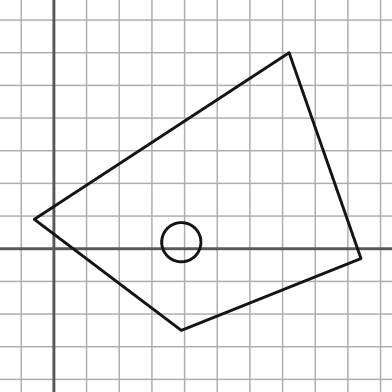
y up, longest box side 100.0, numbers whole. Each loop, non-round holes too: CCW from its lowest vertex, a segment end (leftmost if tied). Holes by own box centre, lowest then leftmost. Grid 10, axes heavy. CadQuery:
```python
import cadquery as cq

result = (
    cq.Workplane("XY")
    .moveTo(39.0, -25.0)
    .lineTo(94.0, -3.0)
    .lineTo(72.0, 60.0)
    .lineTo(-6.0, 9.0)
    .close()
    .moveTo(39.0, 2.0)
    .circle(6.0)
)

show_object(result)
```